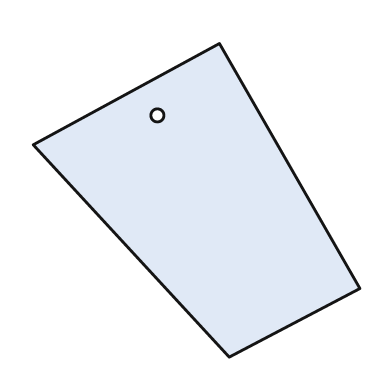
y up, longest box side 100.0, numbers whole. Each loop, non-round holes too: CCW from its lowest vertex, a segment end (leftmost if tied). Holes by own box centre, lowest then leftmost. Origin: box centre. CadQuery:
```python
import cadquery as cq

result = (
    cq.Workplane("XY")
    .moveTo(10.0, -48.0)
    .lineTo(50.0, -27.0)
    .lineTo(7.0, 48.0)
    .lineTo(-50.0, 17.0)
    .close()
    .moveTo(-12.0, 26.0)
    .circle(2.0)
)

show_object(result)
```